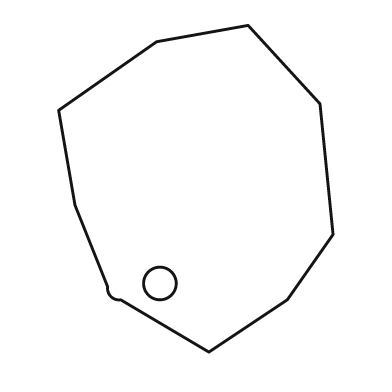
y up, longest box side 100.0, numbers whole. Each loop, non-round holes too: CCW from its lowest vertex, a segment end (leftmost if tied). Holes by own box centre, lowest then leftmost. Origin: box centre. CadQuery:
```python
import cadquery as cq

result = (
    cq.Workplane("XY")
    .moveTo(4.0, -50.0)
    .lineTo(28.0, -34.0)
    .lineTo(42.0, -14.0)
    .lineTo(38.0, 26.0)
    .lineTo(16.0, 50.0)
    .lineTo(-12.0, 45.0)
    .lineTo(-42.0, 24.0)
    .lineTo(-37.0, -5.0)
    .lineTo(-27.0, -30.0)
    .threePointArc((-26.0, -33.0), (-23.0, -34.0))
    .close()
    .moveTo(-11.0, -29.0)
    .circle(5.0)
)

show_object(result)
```